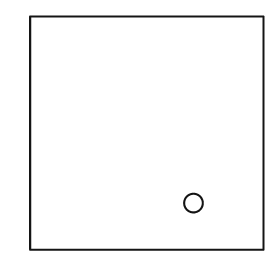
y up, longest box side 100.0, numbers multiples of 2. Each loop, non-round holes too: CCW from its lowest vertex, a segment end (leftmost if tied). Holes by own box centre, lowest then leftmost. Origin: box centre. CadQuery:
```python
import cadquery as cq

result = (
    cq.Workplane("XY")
    .moveTo(-50.0, -50.0)
    .lineTo(50.0, -50.0)
    .lineTo(50.0, 50.0)
    .lineTo(-50.0, 50.0)
    .close()
    .moveTo(20.0, -30.0)
    .circle(4.0)
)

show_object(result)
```